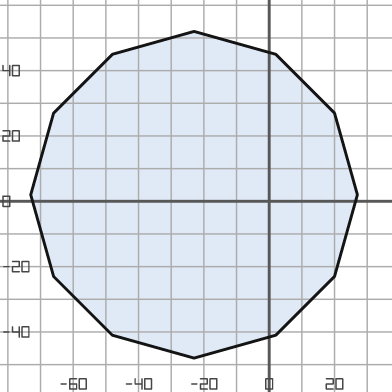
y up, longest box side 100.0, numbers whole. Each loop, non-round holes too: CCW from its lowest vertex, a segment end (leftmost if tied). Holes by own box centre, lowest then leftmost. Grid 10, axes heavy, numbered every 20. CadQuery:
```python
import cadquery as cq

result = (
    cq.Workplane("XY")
    .moveTo(-23.0, -48.0)
    .lineTo(2.0, -41.0)
    .lineTo(20.0, -23.0)
    .lineTo(27.0, 2.0)
    .lineTo(20.0, 27.0)
    .lineTo(2.0, 45.0)
    .lineTo(-23.0, 52.0)
    .lineTo(-48.0, 45.0)
    .lineTo(-66.0, 27.0)
    .lineTo(-73.0, 2.0)
    .lineTo(-66.0, -23.0)
    .lineTo(-48.0, -41.0)
    .close()
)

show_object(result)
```